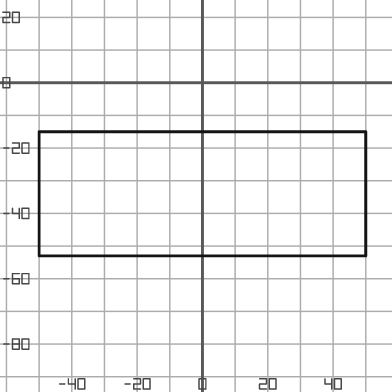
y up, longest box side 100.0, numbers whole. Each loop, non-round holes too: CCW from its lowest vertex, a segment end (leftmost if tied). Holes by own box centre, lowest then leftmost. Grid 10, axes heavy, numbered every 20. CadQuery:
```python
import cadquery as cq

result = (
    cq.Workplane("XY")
    .moveTo(-50.0, -53.0)
    .lineTo(50.0, -53.0)
    .lineTo(50.0, -15.0)
    .lineTo(-50.0, -15.0)
    .close()
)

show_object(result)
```